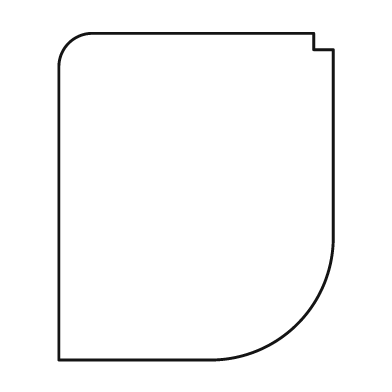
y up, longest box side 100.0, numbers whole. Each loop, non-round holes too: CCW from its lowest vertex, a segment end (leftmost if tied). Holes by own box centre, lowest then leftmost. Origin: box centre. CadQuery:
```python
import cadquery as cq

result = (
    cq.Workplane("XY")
    .moveTo(-42.0, -50.0)
    .lineTo(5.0, -50.0)
    .threePointArc((31.0, -39.0), (42.0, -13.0))
    .lineTo(42.0, 45.0)
    .lineTo(36.0, 45.0)
    .lineTo(36.0, 50.0)
    .lineTo(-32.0, 50.0)
    .threePointArc((-39.0, 47.0), (-42.0, 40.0))
    .close()
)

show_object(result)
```